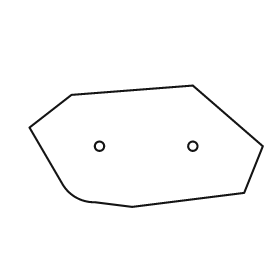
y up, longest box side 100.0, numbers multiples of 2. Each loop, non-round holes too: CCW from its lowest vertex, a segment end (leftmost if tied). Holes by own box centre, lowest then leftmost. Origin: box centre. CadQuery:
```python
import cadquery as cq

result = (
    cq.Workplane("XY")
    .moveTo(-6.0, -26.0)
    .lineTo(42.0, -20.0)
    .lineTo(50.0, 0.0)
    .lineTo(20.0, 26.0)
    .lineTo(-32.0, 22.0)
    .lineTo(-50.0, 8.0)
    .lineTo(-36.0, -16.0)
    .threePointArc((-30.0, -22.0), (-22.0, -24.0))
    .close()
    .moveTo(-20.0, 0.0)
    .circle(2.0)
    .moveTo(20.0, 0.0)
    .circle(2.0)
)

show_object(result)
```